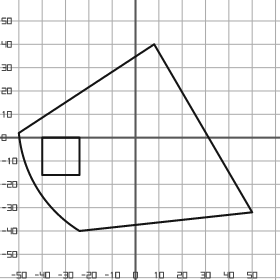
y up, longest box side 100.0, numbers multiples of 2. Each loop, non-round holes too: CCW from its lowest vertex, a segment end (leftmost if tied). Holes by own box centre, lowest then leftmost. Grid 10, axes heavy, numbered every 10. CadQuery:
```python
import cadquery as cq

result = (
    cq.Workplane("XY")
    .moveTo(-24.0, -40.0)
    .lineTo(50.0, -32.0)
    .lineTo(8.0, 40.0)
    .lineTo(-50.0, 2.0)
    .threePointArc((-42.0, -22.0), (-24.0, -40.0))
    .close()
    .moveTo(-40.0, -16.0)
    .lineTo(-24.0, -16.0)
    .lineTo(-24.0, 0.0)
    .lineTo(-40.0, 0.0)
    .close()
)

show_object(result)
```